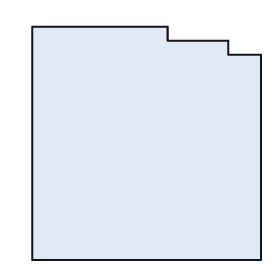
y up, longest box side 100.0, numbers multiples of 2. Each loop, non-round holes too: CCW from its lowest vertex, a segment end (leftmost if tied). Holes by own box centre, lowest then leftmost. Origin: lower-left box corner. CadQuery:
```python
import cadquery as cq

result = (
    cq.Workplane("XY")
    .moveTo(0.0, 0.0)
    .lineTo(98.0, 0.0)
    .lineTo(98.0, 88.0)
    .lineTo(84.0, 88.0)
    .lineTo(84.0, 94.0)
    .lineTo(58.0, 94.0)
    .lineTo(58.0, 100.0)
    .lineTo(0.0, 100.0)
    .close()
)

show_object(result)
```